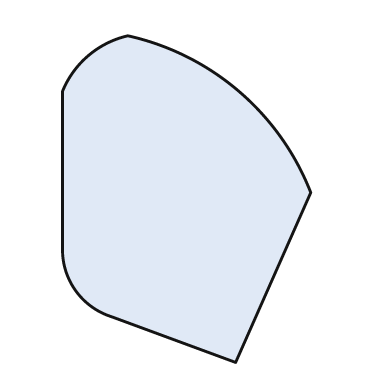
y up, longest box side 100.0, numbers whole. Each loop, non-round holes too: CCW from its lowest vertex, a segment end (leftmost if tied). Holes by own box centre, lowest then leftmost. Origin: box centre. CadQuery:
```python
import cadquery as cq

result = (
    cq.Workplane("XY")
    .moveTo(15.0, -50.0)
    .lineTo(38.0, 2.0)
    .threePointArc((16.0, 33.0), (-18.0, 50.0))
    .threePointArc((-30.0, 44.0), (-38.0, 33.0))
    .lineTo(-38.0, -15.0)
    .threePointArc((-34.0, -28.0), (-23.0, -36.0))
    .close()
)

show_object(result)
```